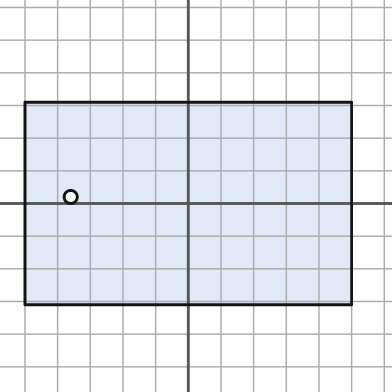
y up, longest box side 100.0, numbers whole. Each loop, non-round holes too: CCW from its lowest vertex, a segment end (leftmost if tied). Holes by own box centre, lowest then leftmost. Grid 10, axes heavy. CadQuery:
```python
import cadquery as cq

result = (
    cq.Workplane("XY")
    .moveTo(-50.0, -31.0)
    .lineTo(50.0, -31.0)
    .lineTo(50.0, 31.0)
    .lineTo(-50.0, 31.0)
    .close()
    .moveTo(-36.0, 2.0)
    .circle(2.0)
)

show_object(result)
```